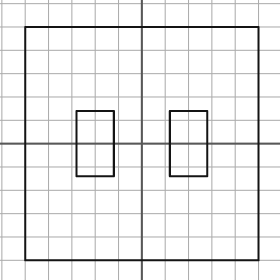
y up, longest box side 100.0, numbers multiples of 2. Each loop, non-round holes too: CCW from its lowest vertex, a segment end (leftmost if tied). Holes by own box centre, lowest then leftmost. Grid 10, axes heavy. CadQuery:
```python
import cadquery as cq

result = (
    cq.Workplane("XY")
    .moveTo(-50.0, -50.0)
    .lineTo(50.0, -50.0)
    .lineTo(50.0, 50.0)
    .lineTo(-50.0, 50.0)
    .close()
    .moveTo(-28.0, -14.0)
    .lineTo(-12.0, -14.0)
    .lineTo(-12.0, 14.0)
    .lineTo(-28.0, 14.0)
    .close()
    .moveTo(12.0, -14.0)
    .lineTo(28.0, -14.0)
    .lineTo(28.0, 14.0)
    .lineTo(12.0, 14.0)
    .close()
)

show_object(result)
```